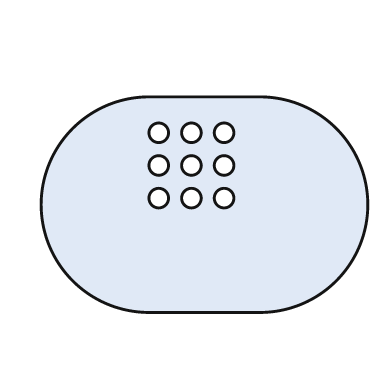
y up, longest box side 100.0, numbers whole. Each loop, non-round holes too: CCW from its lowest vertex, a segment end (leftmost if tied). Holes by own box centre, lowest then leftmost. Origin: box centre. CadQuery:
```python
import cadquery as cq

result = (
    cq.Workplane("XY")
    .moveTo(-17.0, -33.0)
    .lineTo(17.0, -33.0)
    .threePointArc((50.0, 0.0), (17.0, 33.0))
    .lineTo(-17.0, 33.0)
    .threePointArc((-50.0, 0.0), (-17.0, -33.0))
    .close()
    .moveTo(-14.0, 2.0)
    .circle(3.0)
    .moveTo(-4.0, 2.0)
    .circle(3.0)
    .moveTo(6.0, 2.0)
    .circle(3.0)
    .moveTo(-14.0, 12.0)
    .circle(3.0)
    .moveTo(-4.0, 12.0)
    .circle(3.0)
    .moveTo(6.0, 12.0)
    .circle(3.0)
    .moveTo(-14.0, 22.0)
    .circle(3.0)
    .moveTo(-4.0, 22.0)
    .circle(3.0)
    .moveTo(6.0, 22.0)
    .circle(3.0)
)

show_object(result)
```